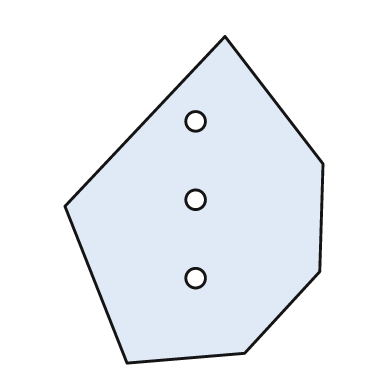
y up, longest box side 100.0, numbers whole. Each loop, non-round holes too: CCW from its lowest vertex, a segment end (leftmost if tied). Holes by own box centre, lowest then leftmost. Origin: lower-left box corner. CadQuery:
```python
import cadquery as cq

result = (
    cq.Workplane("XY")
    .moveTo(19.0, 0.0)
    .lineTo(55.0, 3.0)
    .lineTo(78.0, 28.0)
    .lineTo(79.0, 61.0)
    .lineTo(49.0, 100.0)
    .lineTo(0.0, 48.0)
    .close()
    .moveTo(40.0, 26.0)
    .circle(3.0)
    .moveTo(40.0, 50.0)
    .circle(3.0)
    .moveTo(40.0, 74.0)
    .circle(3.0)
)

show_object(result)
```